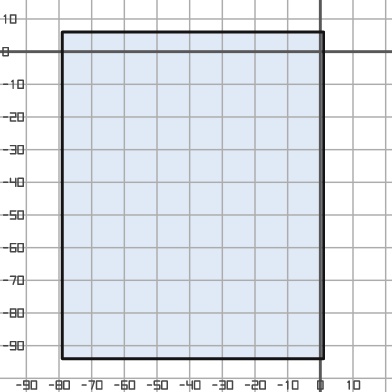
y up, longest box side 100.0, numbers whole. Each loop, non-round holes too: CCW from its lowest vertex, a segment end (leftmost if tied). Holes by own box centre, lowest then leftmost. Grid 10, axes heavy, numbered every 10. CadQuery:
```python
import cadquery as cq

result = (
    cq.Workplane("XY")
    .moveTo(-79.0, -94.0)
    .lineTo(1.0, -94.0)
    .lineTo(1.0, 6.0)
    .lineTo(-79.0, 6.0)
    .close()
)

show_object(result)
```